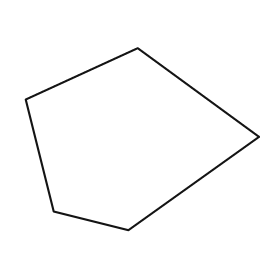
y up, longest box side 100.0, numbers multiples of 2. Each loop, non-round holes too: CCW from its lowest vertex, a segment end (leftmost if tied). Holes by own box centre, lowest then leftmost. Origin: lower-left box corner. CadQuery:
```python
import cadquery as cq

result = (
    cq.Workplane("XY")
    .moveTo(44.0, 0.0)
    .lineTo(100.0, 40.0)
    .lineTo(48.0, 78.0)
    .lineTo(0.0, 56.0)
    .lineTo(12.0, 8.0)
    .close()
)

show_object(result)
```